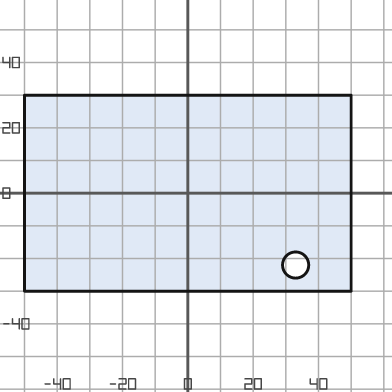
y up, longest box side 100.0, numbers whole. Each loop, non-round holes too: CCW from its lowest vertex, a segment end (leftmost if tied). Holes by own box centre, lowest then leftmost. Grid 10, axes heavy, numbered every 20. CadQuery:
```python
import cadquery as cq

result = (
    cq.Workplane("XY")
    .moveTo(-50.0, -30.0)
    .lineTo(50.0, -30.0)
    .lineTo(50.0, 30.0)
    .lineTo(-50.0, 30.0)
    .close()
    .moveTo(33.0, -22.0)
    .circle(4.0)
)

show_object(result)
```